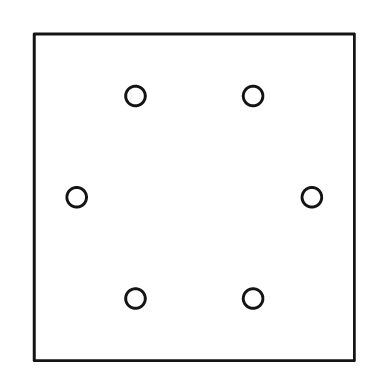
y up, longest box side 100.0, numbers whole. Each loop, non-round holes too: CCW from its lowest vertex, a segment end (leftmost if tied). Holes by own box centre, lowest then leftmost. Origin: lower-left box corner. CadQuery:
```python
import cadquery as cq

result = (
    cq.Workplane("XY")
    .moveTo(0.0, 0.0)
    .lineTo(98.0, 0.0)
    .lineTo(98.0, 100.0)
    .lineTo(0.0, 100.0)
    .close()
    .moveTo(31.0, 19.0)
    .circle(3.0)
    .moveTo(67.0, 19.0)
    .circle(3.0)
    .moveTo(13.0, 50.0)
    .circle(3.0)
    .moveTo(85.0, 50.0)
    .circle(3.0)
    .moveTo(31.0, 81.0)
    .circle(3.0)
    .moveTo(67.0, 81.0)
    .circle(3.0)
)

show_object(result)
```